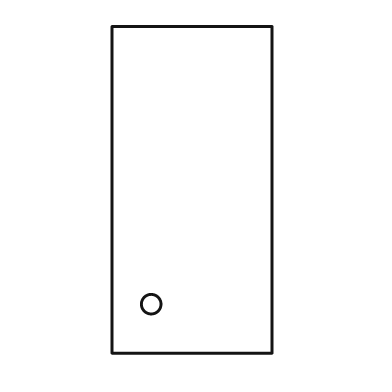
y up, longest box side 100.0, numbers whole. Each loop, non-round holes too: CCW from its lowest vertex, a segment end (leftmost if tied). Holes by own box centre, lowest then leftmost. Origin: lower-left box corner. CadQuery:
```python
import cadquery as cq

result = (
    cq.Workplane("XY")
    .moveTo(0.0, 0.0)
    .lineTo(49.0, 0.0)
    .lineTo(49.0, 100.0)
    .lineTo(0.0, 100.0)
    .close()
    .moveTo(12.0, 15.0)
    .circle(3.0)
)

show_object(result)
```